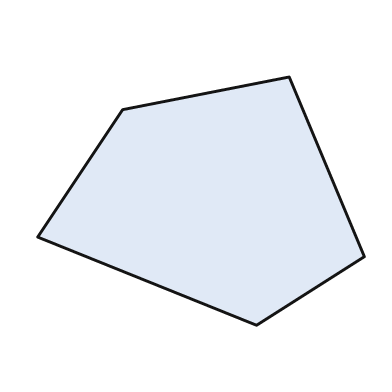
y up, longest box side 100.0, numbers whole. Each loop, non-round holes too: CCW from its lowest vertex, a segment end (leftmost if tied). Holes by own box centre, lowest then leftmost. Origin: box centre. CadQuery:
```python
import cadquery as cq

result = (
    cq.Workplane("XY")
    .moveTo(17.0, -38.0)
    .lineTo(50.0, -17.0)
    .lineTo(27.0, 38.0)
    .lineTo(-24.0, 28.0)
    .lineTo(-50.0, -11.0)
    .close()
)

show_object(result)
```